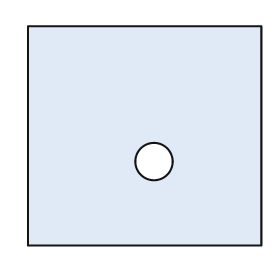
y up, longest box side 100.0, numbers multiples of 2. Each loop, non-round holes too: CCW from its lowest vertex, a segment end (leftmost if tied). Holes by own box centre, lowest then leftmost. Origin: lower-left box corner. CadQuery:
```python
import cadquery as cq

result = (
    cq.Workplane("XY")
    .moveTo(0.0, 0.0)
    .lineTo(100.0, 0.0)
    .lineTo(100.0, 94.0)
    .lineTo(0.0, 94.0)
    .close()
    .moveTo(54.0, 36.0)
    .circle(8.0)
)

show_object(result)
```